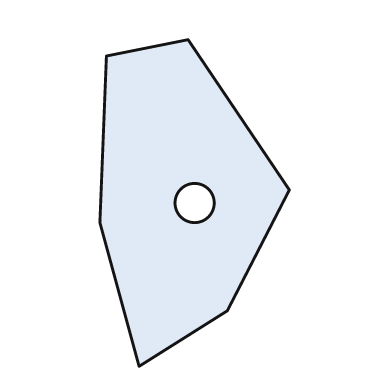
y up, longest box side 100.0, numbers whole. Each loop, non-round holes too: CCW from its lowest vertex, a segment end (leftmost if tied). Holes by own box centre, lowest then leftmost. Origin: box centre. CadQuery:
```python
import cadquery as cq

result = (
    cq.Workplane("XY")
    .moveTo(-17.0, -50.0)
    .lineTo(10.0, -33.0)
    .lineTo(29.0, 4.0)
    .lineTo(-2.0, 50.0)
    .lineTo(-27.0, 45.0)
    .lineTo(-29.0, -6.0)
    .close()
    .moveTo(0.0, 0.0)
    .circle(6.0)
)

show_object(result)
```